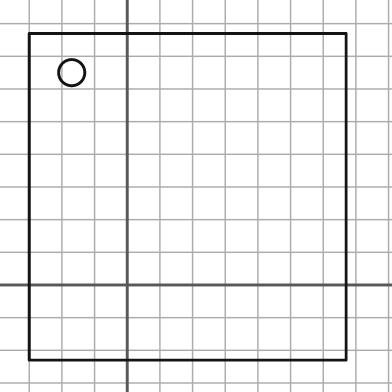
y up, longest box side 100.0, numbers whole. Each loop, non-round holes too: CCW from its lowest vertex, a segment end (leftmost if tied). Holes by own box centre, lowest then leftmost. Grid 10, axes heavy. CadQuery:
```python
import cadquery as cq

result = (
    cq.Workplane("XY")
    .moveTo(-30.0, -23.0)
    .lineTo(67.0, -23.0)
    .lineTo(67.0, 77.0)
    .lineTo(-30.0, 77.0)
    .close()
    .moveTo(-17.0, 65.0)
    .circle(4.0)
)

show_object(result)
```